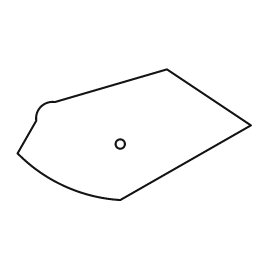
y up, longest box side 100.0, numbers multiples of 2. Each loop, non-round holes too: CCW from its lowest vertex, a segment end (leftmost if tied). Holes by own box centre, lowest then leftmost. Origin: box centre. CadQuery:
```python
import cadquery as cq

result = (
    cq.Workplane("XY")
    .moveTo(-6.0, -28.0)
    .lineTo(50.0, 4.0)
    .lineTo(14.0, 28.0)
    .lineTo(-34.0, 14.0)
    .threePointArc((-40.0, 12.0), (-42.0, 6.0))
    .lineTo(-50.0, -8.0)
    .threePointArc((-30.0, -22.0), (-6.0, -28.0))
    .close()
    .moveTo(-6.0, -4.0)
    .circle(2.0)
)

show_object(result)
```